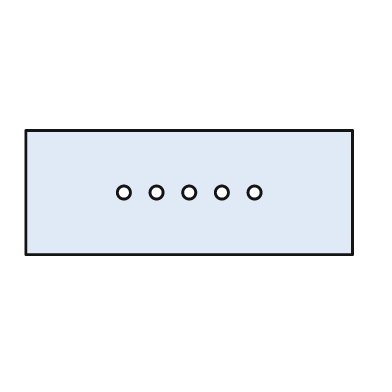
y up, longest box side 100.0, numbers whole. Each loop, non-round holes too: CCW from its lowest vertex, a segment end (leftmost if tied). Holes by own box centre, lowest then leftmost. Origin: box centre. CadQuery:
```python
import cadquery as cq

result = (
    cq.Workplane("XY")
    .moveTo(-50.0, -19.0)
    .lineTo(50.0, -19.0)
    .lineTo(50.0, 19.0)
    .lineTo(-50.0, 19.0)
    .close()
    .moveTo(-20.0, 0.0)
    .circle(2.0)
    .moveTo(-10.0, 0.0)
    .circle(2.0)
    .moveTo(0.0, 0.0)
    .circle(2.0)
    .moveTo(10.0, 0.0)
    .circle(2.0)
    .moveTo(20.0, 0.0)
    .circle(2.0)
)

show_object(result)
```